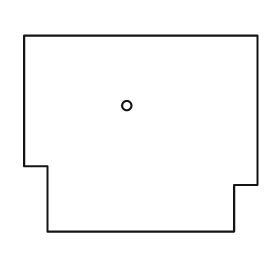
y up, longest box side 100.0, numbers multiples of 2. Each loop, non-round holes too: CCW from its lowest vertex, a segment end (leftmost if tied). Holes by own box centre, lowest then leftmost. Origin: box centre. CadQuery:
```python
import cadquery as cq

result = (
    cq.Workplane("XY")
    .moveTo(-40.0, -42.0)
    .lineTo(40.0, -42.0)
    .lineTo(40.0, -22.0)
    .lineTo(50.0, -22.0)
    .lineTo(50.0, 42.0)
    .lineTo(-50.0, 42.0)
    .lineTo(-50.0, -14.0)
    .lineTo(-40.0, -14.0)
    .close()
    .moveTo(-6.0, 12.0)
    .circle(2.0)
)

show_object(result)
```